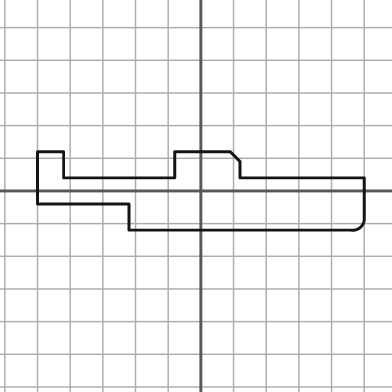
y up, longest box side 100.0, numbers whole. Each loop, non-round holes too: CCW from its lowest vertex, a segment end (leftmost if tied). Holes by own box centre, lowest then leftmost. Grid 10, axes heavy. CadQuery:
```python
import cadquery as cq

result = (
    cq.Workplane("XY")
    .moveTo(-22.0, -12.0)
    .lineTo(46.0, -12.0)
    .threePointArc((49.0, -11.0), (50.0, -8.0))
    .lineTo(50.0, 4.0)
    .lineTo(12.0, 4.0)
    .lineTo(12.0, 9.0)
    .lineTo(9.0, 12.0)
    .lineTo(-8.0, 12.0)
    .lineTo(-8.0, 4.0)
    .lineTo(-42.0, 4.0)
    .lineTo(-42.0, 12.0)
    .lineTo(-50.0, 12.0)
    .lineTo(-50.0, -4.0)
    .lineTo(-22.0, -4.0)
    .close()
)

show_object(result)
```